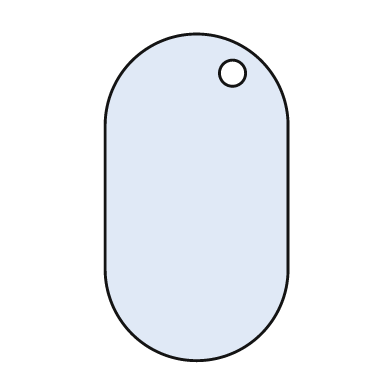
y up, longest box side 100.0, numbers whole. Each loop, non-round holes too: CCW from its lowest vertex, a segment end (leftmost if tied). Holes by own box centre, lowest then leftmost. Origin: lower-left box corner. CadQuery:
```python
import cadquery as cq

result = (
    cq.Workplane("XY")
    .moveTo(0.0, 28.0)
    .threePointArc((28.0, 0.0), (56.0, 28.0))
    .lineTo(56.0, 72.0)
    .threePointArc((28.0, 100.0), (0.0, 72.0))
    .close()
    .moveTo(39.0, 88.0)
    .circle(4.0)
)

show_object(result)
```